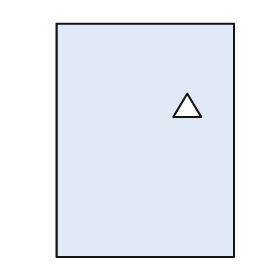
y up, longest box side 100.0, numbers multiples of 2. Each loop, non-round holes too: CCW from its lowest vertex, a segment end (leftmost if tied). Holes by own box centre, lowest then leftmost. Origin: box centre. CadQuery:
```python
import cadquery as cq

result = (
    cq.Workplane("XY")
    .moveTo(-38.0, -50.0)
    .lineTo(38.0, -50.0)
    .lineTo(38.0, 50.0)
    .lineTo(-38.0, 50.0)
    .close()
    .moveTo(12.0, 10.0)
    .lineTo(24.0, 10.0)
    .lineTo(18.0, 20.0)
    .close()
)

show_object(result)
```